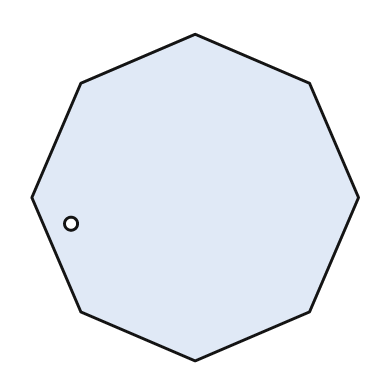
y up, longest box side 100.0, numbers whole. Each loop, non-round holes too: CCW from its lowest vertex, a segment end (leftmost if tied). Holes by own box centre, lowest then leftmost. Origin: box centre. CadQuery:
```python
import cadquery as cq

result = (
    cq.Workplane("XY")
    .moveTo(0.0, -50.0)
    .lineTo(35.0, -35.0)
    .lineTo(50.0, 0.0)
    .lineTo(35.0, 35.0)
    .lineTo(0.0, 50.0)
    .lineTo(-35.0, 35.0)
    .lineTo(-50.0, 0.0)
    .lineTo(-35.0, -35.0)
    .close()
    .moveTo(-38.0, -8.0)
    .circle(2.0)
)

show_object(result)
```